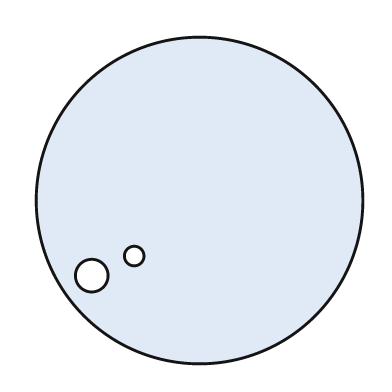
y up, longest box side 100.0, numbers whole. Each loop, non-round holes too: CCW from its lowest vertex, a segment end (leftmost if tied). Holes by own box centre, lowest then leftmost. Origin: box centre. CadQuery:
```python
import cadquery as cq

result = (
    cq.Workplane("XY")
    .moveTo(0.0, 0.0)
    .circle(50.0)
    .moveTo(-33.0, -23.0)
    .circle(5.0)
    .moveTo(-20.0, -17.0)
    .circle(3.0)
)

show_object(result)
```